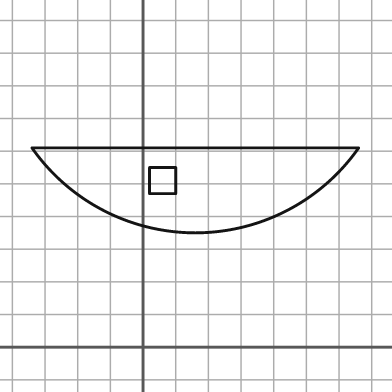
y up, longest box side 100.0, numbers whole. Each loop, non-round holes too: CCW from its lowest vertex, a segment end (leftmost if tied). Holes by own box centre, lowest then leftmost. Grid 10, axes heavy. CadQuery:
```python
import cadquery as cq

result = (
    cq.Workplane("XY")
    .moveTo(-34.0, 61.0)
    .threePointArc((16.0, 35.0), (66.0, 61.0))
    .close()
    .moveTo(2.0, 47.0)
    .lineTo(10.0, 47.0)
    .lineTo(10.0, 55.0)
    .lineTo(2.0, 55.0)
    .close()
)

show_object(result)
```